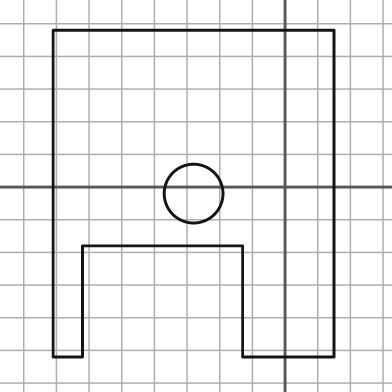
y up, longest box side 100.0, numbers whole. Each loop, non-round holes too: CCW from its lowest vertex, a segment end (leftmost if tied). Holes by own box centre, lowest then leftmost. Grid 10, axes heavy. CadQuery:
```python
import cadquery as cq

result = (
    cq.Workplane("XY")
    .moveTo(-71.0, -52.0)
    .lineTo(-62.0, -52.0)
    .lineTo(-62.0, -18.0)
    .lineTo(-13.0, -18.0)
    .lineTo(-13.0, -52.0)
    .lineTo(15.0, -52.0)
    .lineTo(15.0, 48.0)
    .lineTo(-71.0, 48.0)
    .close()
    .moveTo(-28.0, -2.0)
    .circle(9.0)
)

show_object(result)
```